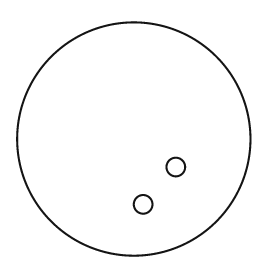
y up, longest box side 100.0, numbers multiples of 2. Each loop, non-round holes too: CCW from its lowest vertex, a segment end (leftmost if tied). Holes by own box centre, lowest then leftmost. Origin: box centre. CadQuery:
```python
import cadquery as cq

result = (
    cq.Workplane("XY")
    .moveTo(0.0, 0.0)
    .circle(50.0)
    .moveTo(4.0, -28.0)
    .circle(4.0)
    .moveTo(18.0, -12.0)
    .circle(4.0)
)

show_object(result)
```